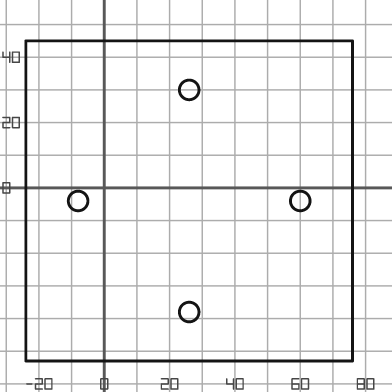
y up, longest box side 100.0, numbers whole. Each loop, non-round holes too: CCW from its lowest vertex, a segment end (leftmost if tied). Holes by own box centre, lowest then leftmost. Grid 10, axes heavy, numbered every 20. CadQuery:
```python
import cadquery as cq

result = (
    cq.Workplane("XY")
    .moveTo(-24.0, -53.0)
    .lineTo(76.0, -53.0)
    .lineTo(76.0, 45.0)
    .lineTo(-24.0, 45.0)
    .close()
    .moveTo(26.0, -38.0)
    .circle(3.0)
    .moveTo(-8.0, -4.0)
    .circle(3.0)
    .moveTo(60.0, -4.0)
    .circle(3.0)
    .moveTo(26.0, 30.0)
    .circle(3.0)
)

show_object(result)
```